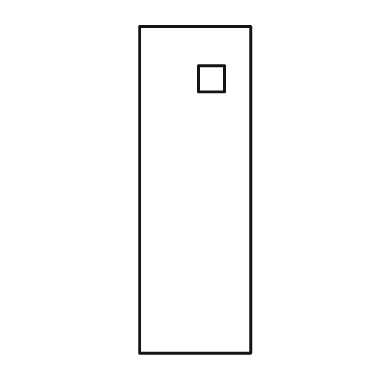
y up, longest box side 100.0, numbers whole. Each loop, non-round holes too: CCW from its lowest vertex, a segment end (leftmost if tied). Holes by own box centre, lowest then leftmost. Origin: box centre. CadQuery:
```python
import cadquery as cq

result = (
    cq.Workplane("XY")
    .moveTo(-17.0, -50.0)
    .lineTo(17.0, -50.0)
    .lineTo(17.0, 50.0)
    .lineTo(-17.0, 50.0)
    .close()
    .moveTo(1.0, 30.0)
    .lineTo(9.0, 30.0)
    .lineTo(9.0, 38.0)
    .lineTo(1.0, 38.0)
    .close()
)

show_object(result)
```